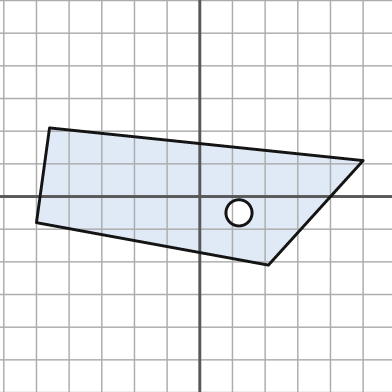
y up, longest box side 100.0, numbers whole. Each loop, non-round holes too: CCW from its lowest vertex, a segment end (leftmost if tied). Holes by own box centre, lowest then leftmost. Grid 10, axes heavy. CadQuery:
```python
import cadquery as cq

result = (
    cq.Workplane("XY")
    .moveTo(21.0, -21.0)
    .lineTo(50.0, 11.0)
    .lineTo(-46.0, 21.0)
    .lineTo(-50.0, -8.0)
    .close()
    .moveTo(12.0, -5.0)
    .circle(4.0)
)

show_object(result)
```